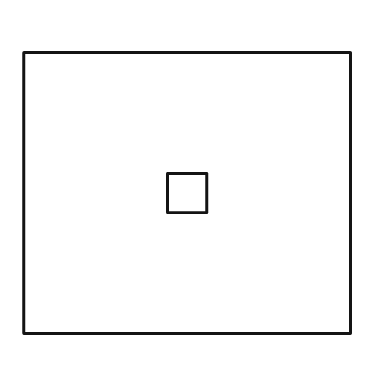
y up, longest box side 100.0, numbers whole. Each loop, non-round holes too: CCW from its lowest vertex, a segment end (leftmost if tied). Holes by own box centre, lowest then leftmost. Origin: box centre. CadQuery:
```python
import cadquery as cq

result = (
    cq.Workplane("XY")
    .moveTo(-50.0, -43.0)
    .lineTo(50.0, -43.0)
    .lineTo(50.0, 43.0)
    .lineTo(-50.0, 43.0)
    .close()
    .moveTo(-6.0, -6.0)
    .lineTo(6.0, -6.0)
    .lineTo(6.0, 6.0)
    .lineTo(-6.0, 6.0)
    .close()
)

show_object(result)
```